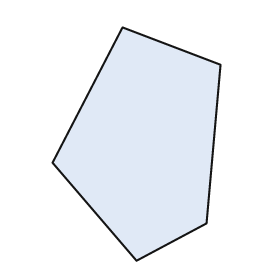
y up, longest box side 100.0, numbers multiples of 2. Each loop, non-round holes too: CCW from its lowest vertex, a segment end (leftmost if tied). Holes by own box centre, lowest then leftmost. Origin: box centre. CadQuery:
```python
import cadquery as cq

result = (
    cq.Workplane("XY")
    .moveTo(0.0, -50.0)
    .lineTo(30.0, -34.0)
    .lineTo(36.0, 34.0)
    .lineTo(-6.0, 50.0)
    .lineTo(-36.0, -8.0)
    .close()
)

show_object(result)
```